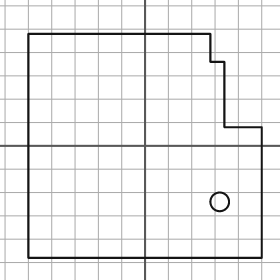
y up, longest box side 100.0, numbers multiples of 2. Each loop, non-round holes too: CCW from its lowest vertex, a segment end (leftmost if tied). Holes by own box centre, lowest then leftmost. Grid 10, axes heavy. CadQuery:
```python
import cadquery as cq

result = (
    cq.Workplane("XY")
    .moveTo(-50.0, -48.0)
    .lineTo(50.0, -48.0)
    .lineTo(50.0, 8.0)
    .lineTo(34.0, 8.0)
    .lineTo(34.0, 36.0)
    .lineTo(28.0, 36.0)
    .lineTo(28.0, 48.0)
    .lineTo(-50.0, 48.0)
    .close()
    .moveTo(32.0, -24.0)
    .circle(4.0)
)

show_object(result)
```